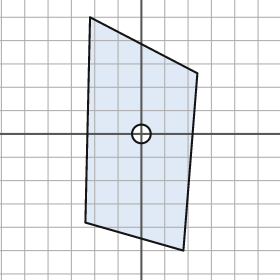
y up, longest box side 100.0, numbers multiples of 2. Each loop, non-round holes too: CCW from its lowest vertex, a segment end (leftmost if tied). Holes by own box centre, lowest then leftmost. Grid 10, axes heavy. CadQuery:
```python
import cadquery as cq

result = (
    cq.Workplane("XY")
    .moveTo(18.0, -50.0)
    .lineTo(24.0, 26.0)
    .lineTo(-22.0, 50.0)
    .lineTo(-24.0, -38.0)
    .close()
    .moveTo(0.0, 0.0)
    .circle(4.0)
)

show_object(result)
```